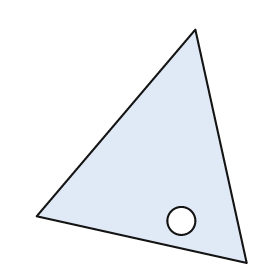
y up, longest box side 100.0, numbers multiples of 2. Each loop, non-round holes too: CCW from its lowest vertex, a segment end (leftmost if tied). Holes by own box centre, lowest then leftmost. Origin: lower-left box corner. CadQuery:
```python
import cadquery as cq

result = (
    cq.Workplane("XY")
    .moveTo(90.0, 0.0)
    .lineTo(68.0, 100.0)
    .lineTo(0.0, 20.0)
    .close()
    .moveTo(62.0, 18.0)
    .circle(6.0)
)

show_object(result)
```